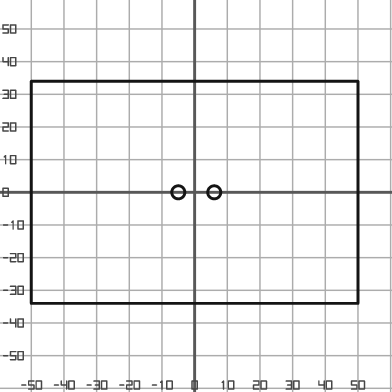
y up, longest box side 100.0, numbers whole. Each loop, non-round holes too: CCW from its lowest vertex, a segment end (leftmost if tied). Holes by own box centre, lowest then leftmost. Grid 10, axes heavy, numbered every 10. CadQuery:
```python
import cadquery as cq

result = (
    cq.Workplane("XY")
    .moveTo(-50.0, -34.0)
    .lineTo(50.0, -34.0)
    .lineTo(50.0, 34.0)
    .lineTo(-50.0, 34.0)
    .close()
    .moveTo(-5.0, 0.0)
    .circle(2.0)
    .moveTo(6.0, 0.0)
    .circle(2.0)
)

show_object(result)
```